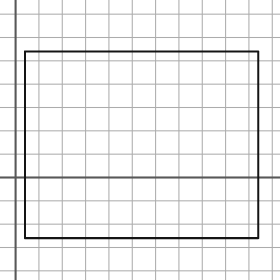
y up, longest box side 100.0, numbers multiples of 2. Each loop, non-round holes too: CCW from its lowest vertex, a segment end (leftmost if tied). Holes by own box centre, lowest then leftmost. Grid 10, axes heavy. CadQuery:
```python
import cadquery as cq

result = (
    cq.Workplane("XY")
    .moveTo(4.0, -26.0)
    .lineTo(104.0, -26.0)
    .lineTo(104.0, 54.0)
    .lineTo(4.0, 54.0)
    .close()
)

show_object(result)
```